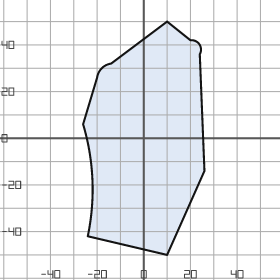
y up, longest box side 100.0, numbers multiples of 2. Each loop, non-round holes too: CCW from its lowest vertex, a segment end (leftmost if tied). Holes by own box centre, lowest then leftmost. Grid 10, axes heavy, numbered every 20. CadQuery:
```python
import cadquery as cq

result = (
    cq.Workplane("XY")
    .moveTo(10.0, -50.0)
    .lineTo(26.0, -14.0)
    .lineTo(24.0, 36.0)
    .threePointArc((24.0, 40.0), (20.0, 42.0))
    .lineTo(10.0, 50.0)
    .lineTo(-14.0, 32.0)
    .threePointArc((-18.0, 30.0), (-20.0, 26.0))
    .lineTo(-26.0, 6.0)
    .threePointArc((-22.0, -18.0), (-24.0, -42.0))
    .close()
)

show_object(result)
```